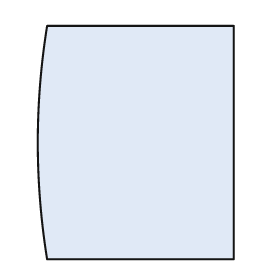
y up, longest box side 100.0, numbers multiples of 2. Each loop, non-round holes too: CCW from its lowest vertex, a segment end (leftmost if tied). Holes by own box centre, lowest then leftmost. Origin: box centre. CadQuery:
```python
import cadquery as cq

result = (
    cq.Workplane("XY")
    .moveTo(-38.0, -50.0)
    .lineTo(42.0, -50.0)
    .lineTo(42.0, 50.0)
    .lineTo(-38.0, 50.0)
    .threePointArc((-42.0, 0.0), (-38.0, -50.0))
    .close()
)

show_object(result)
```